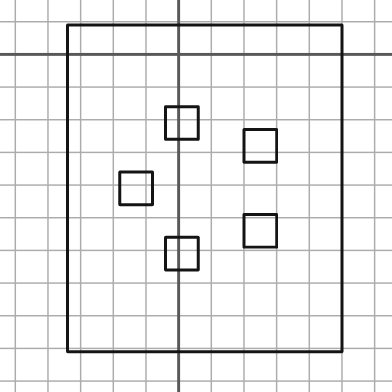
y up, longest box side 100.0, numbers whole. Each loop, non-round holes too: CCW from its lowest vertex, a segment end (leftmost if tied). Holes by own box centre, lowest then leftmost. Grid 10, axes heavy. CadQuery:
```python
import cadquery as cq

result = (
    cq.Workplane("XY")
    .moveTo(-34.0, -91.0)
    .lineTo(50.0, -91.0)
    .lineTo(50.0, 9.0)
    .lineTo(-34.0, 9.0)
    .close()
    .moveTo(-4.0, -66.0)
    .lineTo(6.0, -66.0)
    .lineTo(6.0, -56.0)
    .lineTo(-4.0, -56.0)
    .close()
    .moveTo(20.0, -59.0)
    .lineTo(30.0, -59.0)
    .lineTo(30.0, -49.0)
    .lineTo(20.0, -49.0)
    .close()
    .moveTo(-18.0, -46.0)
    .lineTo(-8.0, -46.0)
    .lineTo(-8.0, -36.0)
    .lineTo(-18.0, -36.0)
    .close()
    .moveTo(20.0, -33.0)
    .lineTo(30.0, -33.0)
    .lineTo(30.0, -23.0)
    .lineTo(20.0, -23.0)
    .close()
    .moveTo(-4.0, -26.0)
    .lineTo(6.0, -26.0)
    .lineTo(6.0, -16.0)
    .lineTo(-4.0, -16.0)
    .close()
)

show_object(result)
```